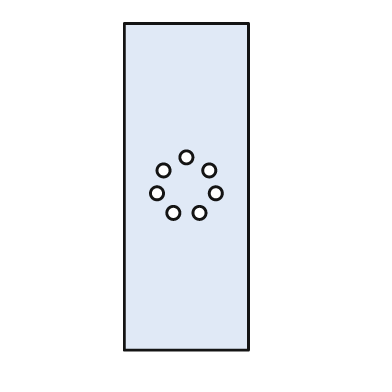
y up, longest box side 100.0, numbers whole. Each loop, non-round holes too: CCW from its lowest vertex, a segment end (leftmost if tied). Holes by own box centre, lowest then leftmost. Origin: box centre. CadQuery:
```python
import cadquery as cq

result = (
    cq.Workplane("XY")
    .moveTo(-19.0, -50.0)
    .lineTo(19.0, -50.0)
    .lineTo(19.0, 50.0)
    .lineTo(-19.0, 50.0)
    .close()
    .moveTo(-4.0, -8.0)
    .circle(2.0)
    .moveTo(4.0, -8.0)
    .circle(2.0)
    .moveTo(-9.0, -2.0)
    .circle(2.0)
    .moveTo(9.0, -2.0)
    .circle(2.0)
    .moveTo(-7.0, 5.0)
    .circle(2.0)
    .moveTo(7.0, 5.0)
    .circle(2.0)
    .moveTo(0.0, 9.0)
    .circle(2.0)
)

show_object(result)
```